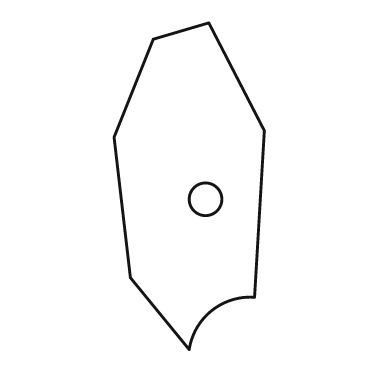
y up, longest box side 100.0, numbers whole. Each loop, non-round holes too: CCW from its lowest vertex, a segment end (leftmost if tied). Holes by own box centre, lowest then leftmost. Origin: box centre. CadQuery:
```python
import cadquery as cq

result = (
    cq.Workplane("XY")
    .moveTo(0.0, -50.0)
    .threePointArc((7.0, -38.0), (20.0, -34.0))
    .lineTo(23.0, 17.0)
    .lineTo(6.0, 50.0)
    .lineTo(-11.0, 45.0)
    .lineTo(-23.0, 15.0)
    .lineTo(-18.0, -28.0)
    .close()
    .moveTo(5.0, -4.0)
    .circle(5.0)
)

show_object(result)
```